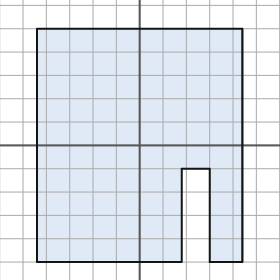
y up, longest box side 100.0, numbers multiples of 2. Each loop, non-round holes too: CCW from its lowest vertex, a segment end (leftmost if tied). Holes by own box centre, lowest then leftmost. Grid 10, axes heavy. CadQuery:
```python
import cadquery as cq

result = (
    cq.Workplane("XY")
    .moveTo(-44.0, -50.0)
    .lineTo(18.0, -50.0)
    .lineTo(18.0, -10.0)
    .lineTo(30.0, -10.0)
    .lineTo(30.0, -50.0)
    .lineTo(44.0, -50.0)
    .lineTo(44.0, 50.0)
    .lineTo(-44.0, 50.0)
    .close()
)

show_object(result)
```